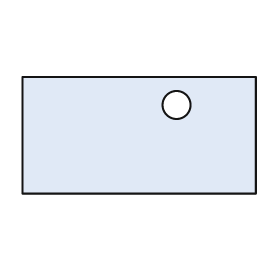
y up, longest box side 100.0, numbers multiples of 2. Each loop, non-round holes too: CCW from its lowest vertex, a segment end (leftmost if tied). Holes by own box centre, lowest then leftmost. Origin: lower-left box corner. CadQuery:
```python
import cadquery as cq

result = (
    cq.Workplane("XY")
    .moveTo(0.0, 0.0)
    .lineTo(100.0, 0.0)
    .lineTo(100.0, 50.0)
    .lineTo(0.0, 50.0)
    .close()
    .moveTo(66.0, 38.0)
    .circle(6.0)
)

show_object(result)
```